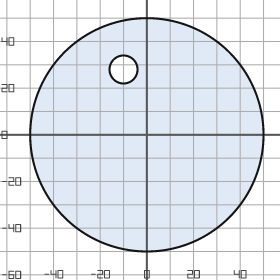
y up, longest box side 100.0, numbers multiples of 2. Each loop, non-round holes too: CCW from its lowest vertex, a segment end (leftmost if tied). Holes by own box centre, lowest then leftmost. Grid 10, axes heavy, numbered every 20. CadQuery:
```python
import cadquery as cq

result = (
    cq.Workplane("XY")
    .moveTo(0.0, 0.0)
    .circle(50.0)
    .moveTo(-10.0, 28.0)
    .circle(6.0)
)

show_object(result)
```